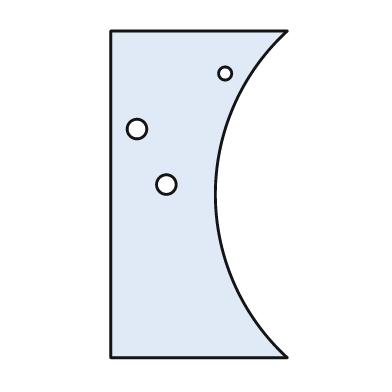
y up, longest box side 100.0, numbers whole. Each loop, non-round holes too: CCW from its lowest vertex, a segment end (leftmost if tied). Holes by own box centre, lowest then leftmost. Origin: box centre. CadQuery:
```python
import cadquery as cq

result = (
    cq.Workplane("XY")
    .moveTo(-27.0, -50.0)
    .lineTo(27.0, -50.0)
    .threePointArc((5.0, 0.0), (27.0, 50.0))
    .lineTo(-27.0, 50.0)
    .close()
    .moveTo(-10.0, 3.0)
    .circle(3.0)
    .moveTo(-19.0, 20.0)
    .circle(3.0)
    .moveTo(8.0, 37.0)
    .circle(2.0)
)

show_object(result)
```